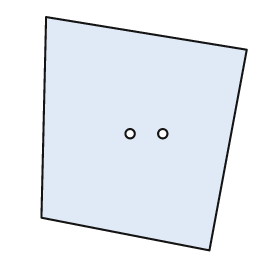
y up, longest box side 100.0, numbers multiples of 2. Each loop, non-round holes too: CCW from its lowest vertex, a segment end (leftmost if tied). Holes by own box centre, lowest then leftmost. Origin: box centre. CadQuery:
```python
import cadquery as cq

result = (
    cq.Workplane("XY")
    .moveTo(28.0, -50.0)
    .lineTo(44.0, 36.0)
    .lineTo(-42.0, 50.0)
    .lineTo(-44.0, -36.0)
    .close()
    .moveTo(-6.0, 0.0)
    .circle(2.0)
    .moveTo(8.0, 0.0)
    .circle(2.0)
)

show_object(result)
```